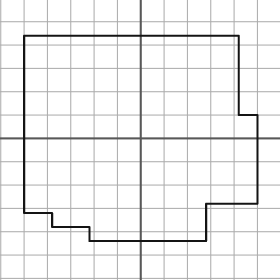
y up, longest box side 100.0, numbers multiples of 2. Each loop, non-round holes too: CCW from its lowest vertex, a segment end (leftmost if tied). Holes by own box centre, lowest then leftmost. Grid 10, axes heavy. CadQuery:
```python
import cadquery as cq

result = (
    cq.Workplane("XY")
    .moveTo(-22.0, -44.0)
    .lineTo(28.0, -44.0)
    .lineTo(28.0, -28.0)
    .lineTo(50.0, -28.0)
    .lineTo(50.0, 10.0)
    .lineTo(42.0, 10.0)
    .lineTo(42.0, 44.0)
    .lineTo(-50.0, 44.0)
    .lineTo(-50.0, -32.0)
    .lineTo(-38.0, -32.0)
    .lineTo(-38.0, -38.0)
    .lineTo(-22.0, -38.0)
    .close()
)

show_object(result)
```